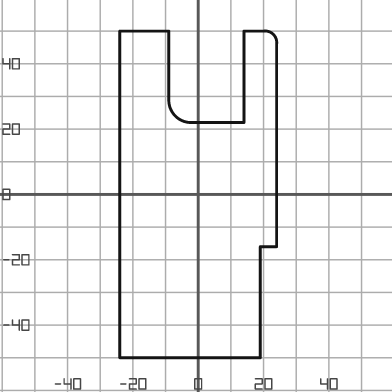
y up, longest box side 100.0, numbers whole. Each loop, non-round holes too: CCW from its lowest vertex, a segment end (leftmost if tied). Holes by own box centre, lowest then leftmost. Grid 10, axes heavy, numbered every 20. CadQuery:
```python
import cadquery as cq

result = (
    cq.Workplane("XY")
    .moveTo(-24.0, -50.0)
    .lineTo(19.0, -50.0)
    .lineTo(19.0, -16.0)
    .lineTo(24.0, -16.0)
    .lineTo(24.0, 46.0)
    .threePointArc((23.0, 49.0), (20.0, 50.0))
    .lineTo(14.0, 50.0)
    .lineTo(14.0, 22.0)
    .lineTo(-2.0, 22.0)
    .threePointArc((-7.0, 24.0), (-9.0, 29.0))
    .lineTo(-9.0, 50.0)
    .lineTo(-24.0, 50.0)
    .close()
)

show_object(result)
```